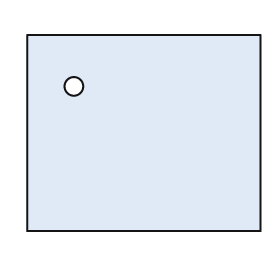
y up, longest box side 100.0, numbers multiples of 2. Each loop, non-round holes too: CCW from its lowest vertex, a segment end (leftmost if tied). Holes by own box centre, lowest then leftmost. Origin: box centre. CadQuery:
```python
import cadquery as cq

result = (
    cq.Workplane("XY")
    .moveTo(-50.0, -42.0)
    .lineTo(50.0, -42.0)
    .lineTo(50.0, 42.0)
    .lineTo(-50.0, 42.0)
    .close()
    .moveTo(-30.0, 20.0)
    .circle(4.0)
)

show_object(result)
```